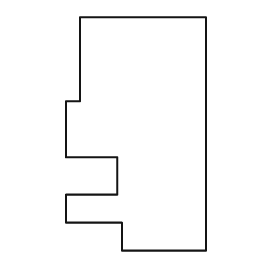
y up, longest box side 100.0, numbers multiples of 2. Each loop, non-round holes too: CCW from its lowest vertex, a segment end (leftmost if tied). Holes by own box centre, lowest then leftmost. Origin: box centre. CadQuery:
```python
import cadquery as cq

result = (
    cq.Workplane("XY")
    .moveTo(-6.0, -50.0)
    .lineTo(30.0, -50.0)
    .lineTo(30.0, 50.0)
    .lineTo(-24.0, 50.0)
    .lineTo(-24.0, 14.0)
    .lineTo(-30.0, 14.0)
    .lineTo(-30.0, -10.0)
    .lineTo(-8.0, -10.0)
    .lineTo(-8.0, -26.0)
    .lineTo(-30.0, -26.0)
    .lineTo(-30.0, -38.0)
    .lineTo(-6.0, -38.0)
    .close()
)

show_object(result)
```